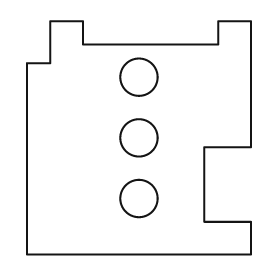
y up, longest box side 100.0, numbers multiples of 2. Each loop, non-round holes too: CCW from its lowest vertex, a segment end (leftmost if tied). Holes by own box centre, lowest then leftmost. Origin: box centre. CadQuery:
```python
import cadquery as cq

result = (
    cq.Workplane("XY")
    .moveTo(-48.0, -50.0)
    .lineTo(48.0, -50.0)
    .lineTo(48.0, -36.0)
    .lineTo(28.0, -36.0)
    .lineTo(28.0, -4.0)
    .lineTo(48.0, -4.0)
    .lineTo(48.0, 50.0)
    .lineTo(34.0, 50.0)
    .lineTo(34.0, 40.0)
    .lineTo(-24.0, 40.0)
    .lineTo(-24.0, 50.0)
    .lineTo(-38.0, 50.0)
    .lineTo(-38.0, 32.0)
    .lineTo(-48.0, 32.0)
    .close()
    .moveTo(0.0, -26.0)
    .circle(8.0)
    .moveTo(0.0, 0.0)
    .circle(8.0)
    .moveTo(0.0, 26.0)
    .circle(8.0)
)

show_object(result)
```